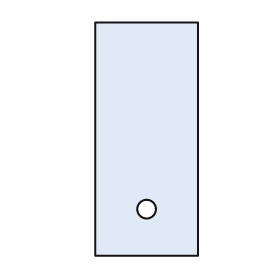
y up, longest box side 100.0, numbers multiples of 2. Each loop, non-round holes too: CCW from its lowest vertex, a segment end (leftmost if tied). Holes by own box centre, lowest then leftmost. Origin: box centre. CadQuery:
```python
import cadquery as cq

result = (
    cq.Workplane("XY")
    .moveTo(-22.0, -50.0)
    .lineTo(22.0, -50.0)
    .lineTo(22.0, 50.0)
    .lineTo(-22.0, 50.0)
    .close()
    .moveTo(0.0, -30.0)
    .circle(4.0)
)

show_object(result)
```